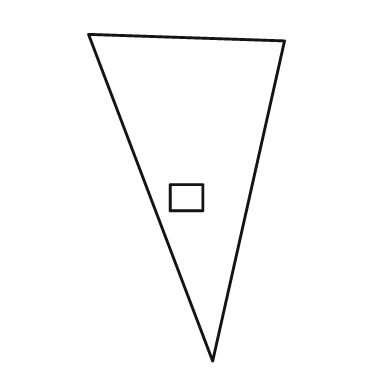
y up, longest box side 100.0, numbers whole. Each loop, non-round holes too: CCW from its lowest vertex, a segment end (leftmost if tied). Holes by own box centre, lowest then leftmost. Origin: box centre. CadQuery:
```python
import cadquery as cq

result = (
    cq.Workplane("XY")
    .moveTo(8.0, -50.0)
    .lineTo(30.0, 48.0)
    .lineTo(-30.0, 50.0)
    .close()
    .moveTo(-5.0, -4.0)
    .lineTo(5.0, -4.0)
    .lineTo(5.0, 4.0)
    .lineTo(-5.0, 4.0)
    .close()
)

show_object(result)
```